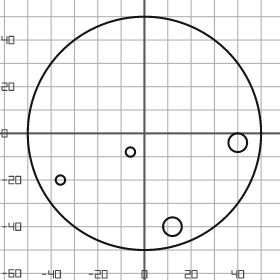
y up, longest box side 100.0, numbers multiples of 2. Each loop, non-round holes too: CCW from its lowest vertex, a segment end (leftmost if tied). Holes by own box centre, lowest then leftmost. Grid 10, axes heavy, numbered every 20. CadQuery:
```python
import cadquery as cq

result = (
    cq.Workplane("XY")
    .moveTo(0.0, 0.0)
    .circle(50.0)
    .moveTo(12.0, -40.0)
    .circle(4.0)
    .moveTo(-36.0, -20.0)
    .circle(2.0)
    .moveTo(-6.0, -8.0)
    .circle(2.0)
    .moveTo(40.0, -4.0)
    .circle(4.0)
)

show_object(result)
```